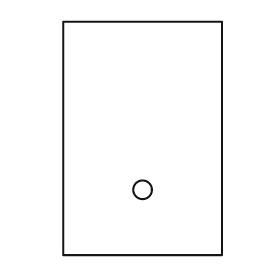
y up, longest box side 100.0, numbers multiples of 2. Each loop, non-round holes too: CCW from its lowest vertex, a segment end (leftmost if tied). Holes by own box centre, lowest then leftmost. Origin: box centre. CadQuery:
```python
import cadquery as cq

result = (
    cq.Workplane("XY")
    .moveTo(-34.0, -50.0)
    .lineTo(34.0, -50.0)
    .lineTo(34.0, 50.0)
    .lineTo(-34.0, 50.0)
    .close()
    .moveTo(0.0, -22.0)
    .circle(4.0)
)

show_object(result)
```